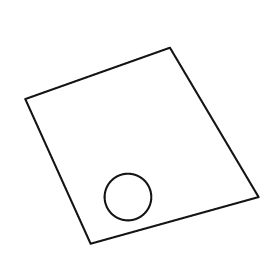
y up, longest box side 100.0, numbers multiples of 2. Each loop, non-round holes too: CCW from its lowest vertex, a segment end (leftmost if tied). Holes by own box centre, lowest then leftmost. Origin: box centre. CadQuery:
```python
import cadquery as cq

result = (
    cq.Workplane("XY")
    .moveTo(-22.0, -42.0)
    .lineTo(50.0, -22.0)
    .lineTo(12.0, 42.0)
    .lineTo(-50.0, 20.0)
    .close()
    .moveTo(-6.0, -22.0)
    .circle(10.0)
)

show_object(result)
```